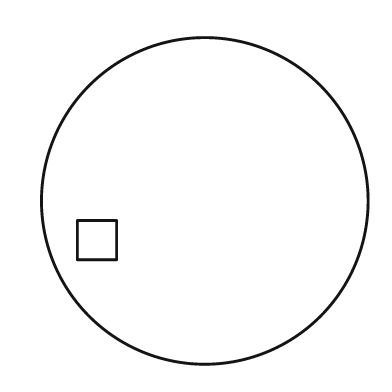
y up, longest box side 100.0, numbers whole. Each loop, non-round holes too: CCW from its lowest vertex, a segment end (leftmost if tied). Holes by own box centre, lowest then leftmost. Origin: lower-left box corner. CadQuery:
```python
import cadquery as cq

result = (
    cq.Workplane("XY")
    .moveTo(50.0, 50.0)
    .circle(50.0)
    .moveTo(11.0, 32.0)
    .lineTo(23.0, 32.0)
    .lineTo(23.0, 44.0)
    .lineTo(11.0, 44.0)
    .close()
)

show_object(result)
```